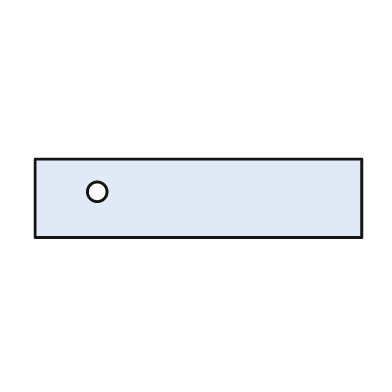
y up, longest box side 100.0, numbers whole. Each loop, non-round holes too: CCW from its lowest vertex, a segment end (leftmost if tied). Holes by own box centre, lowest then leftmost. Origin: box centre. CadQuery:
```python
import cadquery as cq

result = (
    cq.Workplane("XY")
    .moveTo(-50.0, -12.0)
    .lineTo(50.0, -12.0)
    .lineTo(50.0, 12.0)
    .lineTo(-50.0, 12.0)
    .close()
    .moveTo(-31.0, 2.0)
    .circle(3.0)
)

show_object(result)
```